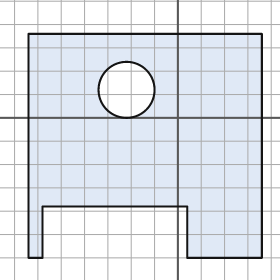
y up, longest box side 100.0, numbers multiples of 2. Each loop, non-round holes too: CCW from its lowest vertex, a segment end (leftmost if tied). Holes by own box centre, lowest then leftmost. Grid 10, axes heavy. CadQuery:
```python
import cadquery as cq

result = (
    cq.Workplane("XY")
    .moveTo(-64.0, -60.0)
    .lineTo(-58.0, -60.0)
    .lineTo(-58.0, -38.0)
    .lineTo(4.0, -38.0)
    .lineTo(4.0, -60.0)
    .lineTo(36.0, -60.0)
    .lineTo(36.0, 36.0)
    .lineTo(-64.0, 36.0)
    .close()
    .moveTo(-22.0, 12.0)
    .circle(12.0)
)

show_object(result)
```